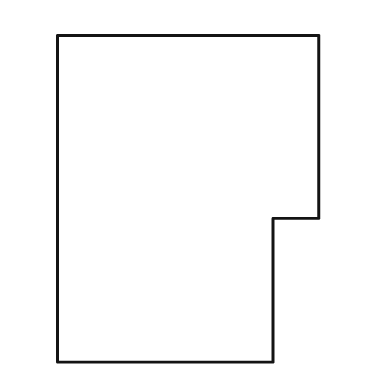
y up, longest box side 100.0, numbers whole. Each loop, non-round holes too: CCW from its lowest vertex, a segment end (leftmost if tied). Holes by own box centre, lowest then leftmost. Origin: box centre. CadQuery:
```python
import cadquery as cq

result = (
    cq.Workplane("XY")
    .moveTo(-40.0, -50.0)
    .lineTo(26.0, -50.0)
    .lineTo(26.0, -6.0)
    .lineTo(40.0, -6.0)
    .lineTo(40.0, 50.0)
    .lineTo(-40.0, 50.0)
    .close()
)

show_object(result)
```